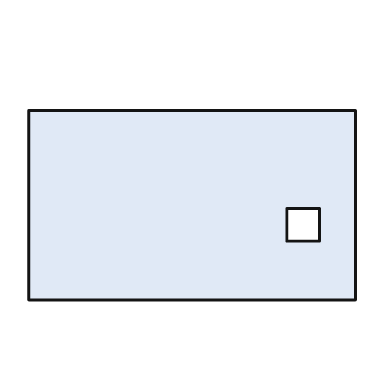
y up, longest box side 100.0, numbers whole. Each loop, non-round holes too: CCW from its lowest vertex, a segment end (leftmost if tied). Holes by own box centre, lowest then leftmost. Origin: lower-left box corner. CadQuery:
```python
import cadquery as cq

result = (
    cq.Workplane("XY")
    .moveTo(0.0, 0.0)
    .lineTo(100.0, 0.0)
    .lineTo(100.0, 58.0)
    .lineTo(0.0, 58.0)
    .close()
    .moveTo(79.0, 18.0)
    .lineTo(89.0, 18.0)
    .lineTo(89.0, 28.0)
    .lineTo(79.0, 28.0)
    .close()
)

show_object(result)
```